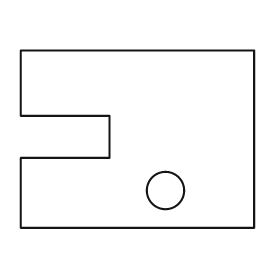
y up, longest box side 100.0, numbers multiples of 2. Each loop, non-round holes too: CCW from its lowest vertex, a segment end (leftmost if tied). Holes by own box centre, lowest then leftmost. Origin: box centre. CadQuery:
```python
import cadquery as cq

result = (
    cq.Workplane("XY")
    .moveTo(-50.0, -38.0)
    .lineTo(50.0, -38.0)
    .lineTo(50.0, 38.0)
    .lineTo(-50.0, 38.0)
    .lineTo(-50.0, 10.0)
    .lineTo(-12.0, 10.0)
    .lineTo(-12.0, -8.0)
    .lineTo(-50.0, -8.0)
    .close()
    .moveTo(12.0, -22.0)
    .circle(8.0)
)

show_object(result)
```